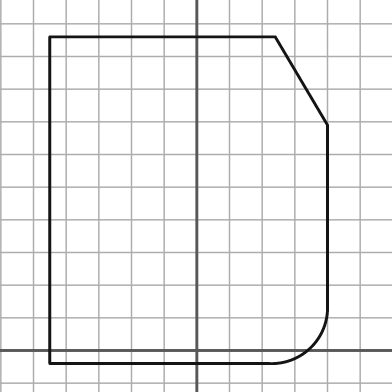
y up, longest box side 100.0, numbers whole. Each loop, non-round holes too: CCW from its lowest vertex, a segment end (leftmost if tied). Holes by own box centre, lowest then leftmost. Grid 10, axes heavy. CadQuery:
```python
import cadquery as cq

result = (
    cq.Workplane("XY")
    .moveTo(-45.0, -4.0)
    .lineTo(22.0, -4.0)
    .threePointArc((35.0, 1.0), (40.0, 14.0))
    .lineTo(40.0, 69.0)
    .lineTo(24.0, 96.0)
    .lineTo(-45.0, 96.0)
    .close()
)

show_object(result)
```